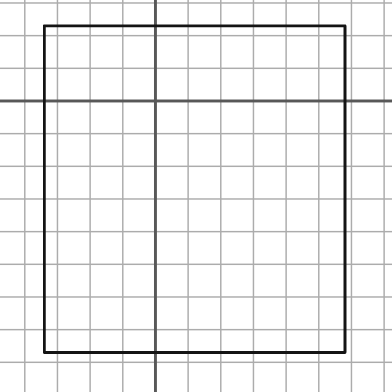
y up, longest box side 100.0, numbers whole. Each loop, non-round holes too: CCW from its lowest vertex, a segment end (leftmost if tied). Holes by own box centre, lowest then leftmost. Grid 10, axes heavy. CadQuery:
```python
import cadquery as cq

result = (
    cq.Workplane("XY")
    .moveTo(-34.0, -77.0)
    .lineTo(58.0, -77.0)
    .lineTo(58.0, 23.0)
    .lineTo(-34.0, 23.0)
    .close()
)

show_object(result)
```